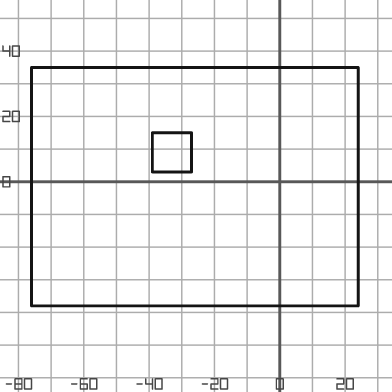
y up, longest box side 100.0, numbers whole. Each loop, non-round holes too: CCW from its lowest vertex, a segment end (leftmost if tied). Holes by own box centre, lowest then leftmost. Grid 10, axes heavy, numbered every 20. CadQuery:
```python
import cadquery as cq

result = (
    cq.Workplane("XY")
    .moveTo(-76.0, -38.0)
    .lineTo(24.0, -38.0)
    .lineTo(24.0, 35.0)
    .lineTo(-76.0, 35.0)
    .close()
    .moveTo(-39.0, 3.0)
    .lineTo(-27.0, 3.0)
    .lineTo(-27.0, 15.0)
    .lineTo(-39.0, 15.0)
    .close()
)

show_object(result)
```